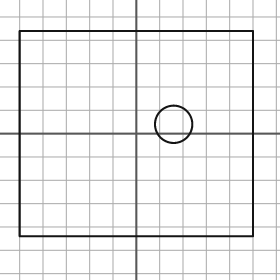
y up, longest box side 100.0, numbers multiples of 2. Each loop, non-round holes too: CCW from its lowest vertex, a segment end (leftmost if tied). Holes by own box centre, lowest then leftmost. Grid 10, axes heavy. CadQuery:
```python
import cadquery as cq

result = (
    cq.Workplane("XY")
    .moveTo(-50.0, -44.0)
    .lineTo(50.0, -44.0)
    .lineTo(50.0, 44.0)
    .lineTo(-50.0, 44.0)
    .close()
    .moveTo(16.0, 4.0)
    .circle(8.0)
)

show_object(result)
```